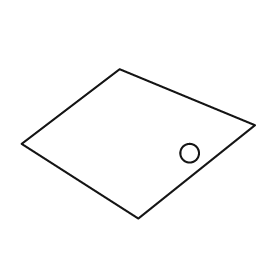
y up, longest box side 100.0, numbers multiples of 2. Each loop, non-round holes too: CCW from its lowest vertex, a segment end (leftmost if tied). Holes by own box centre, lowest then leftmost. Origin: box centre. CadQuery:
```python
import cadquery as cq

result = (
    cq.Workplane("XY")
    .moveTo(0.0, -32.0)
    .lineTo(50.0, 8.0)
    .lineTo(-8.0, 32.0)
    .lineTo(-50.0, 0.0)
    .close()
    .moveTo(22.0, -4.0)
    .circle(4.0)
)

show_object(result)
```